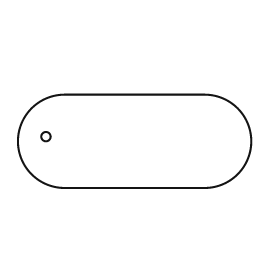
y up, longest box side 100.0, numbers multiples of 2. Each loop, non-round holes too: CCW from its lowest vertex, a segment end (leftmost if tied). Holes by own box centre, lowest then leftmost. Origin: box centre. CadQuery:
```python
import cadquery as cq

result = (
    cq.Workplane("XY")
    .moveTo(-30.0, -20.0)
    .lineTo(30.0, -20.0)
    .threePointArc((50.0, 0.0), (30.0, 20.0))
    .lineTo(-30.0, 20.0)
    .threePointArc((-50.0, 0.0), (-30.0, -20.0))
    .close()
    .moveTo(-38.0, 2.0)
    .circle(2.0)
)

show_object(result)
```